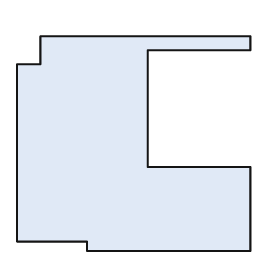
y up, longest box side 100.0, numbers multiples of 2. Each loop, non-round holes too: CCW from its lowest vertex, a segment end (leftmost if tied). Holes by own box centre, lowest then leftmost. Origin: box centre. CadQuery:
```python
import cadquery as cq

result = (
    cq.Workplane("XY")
    .moveTo(-20.0, -46.0)
    .lineTo(50.0, -46.0)
    .lineTo(50.0, -10.0)
    .lineTo(6.0, -10.0)
    .lineTo(6.0, 40.0)
    .lineTo(50.0, 40.0)
    .lineTo(50.0, 46.0)
    .lineTo(-40.0, 46.0)
    .lineTo(-40.0, 34.0)
    .lineTo(-50.0, 34.0)
    .lineTo(-50.0, -42.0)
    .lineTo(-20.0, -42.0)
    .close()
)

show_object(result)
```